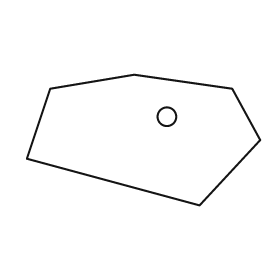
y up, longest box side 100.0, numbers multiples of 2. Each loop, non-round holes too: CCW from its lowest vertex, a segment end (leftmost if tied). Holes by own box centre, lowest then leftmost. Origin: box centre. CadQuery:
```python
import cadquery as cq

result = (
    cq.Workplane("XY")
    .moveTo(24.0, -28.0)
    .lineTo(50.0, 0.0)
    .lineTo(38.0, 22.0)
    .lineTo(-4.0, 28.0)
    .lineTo(-40.0, 22.0)
    .lineTo(-50.0, -8.0)
    .close()
    .moveTo(10.0, 10.0)
    .circle(4.0)
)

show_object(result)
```